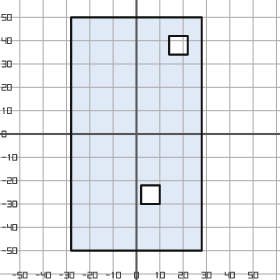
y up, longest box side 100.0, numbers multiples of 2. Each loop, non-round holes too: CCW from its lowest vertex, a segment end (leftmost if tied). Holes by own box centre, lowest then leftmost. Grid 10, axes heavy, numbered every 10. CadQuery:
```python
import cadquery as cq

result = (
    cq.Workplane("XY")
    .moveTo(-28.0, -50.0)
    .lineTo(28.0, -50.0)
    .lineTo(28.0, 50.0)
    .lineTo(-28.0, 50.0)
    .close()
    .moveTo(2.0, -30.0)
    .lineTo(10.0, -30.0)
    .lineTo(10.0, -22.0)
    .lineTo(2.0, -22.0)
    .close()
    .moveTo(14.0, 34.0)
    .lineTo(22.0, 34.0)
    .lineTo(22.0, 42.0)
    .lineTo(14.0, 42.0)
    .close()
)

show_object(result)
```